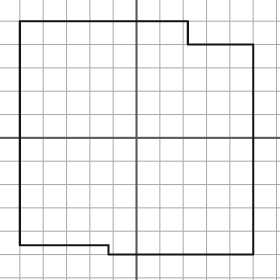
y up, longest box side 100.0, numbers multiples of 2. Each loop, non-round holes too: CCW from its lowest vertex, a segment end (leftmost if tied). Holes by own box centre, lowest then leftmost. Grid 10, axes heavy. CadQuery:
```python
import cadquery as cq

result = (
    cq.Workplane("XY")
    .moveTo(-12.0, -50.0)
    .lineTo(50.0, -50.0)
    .lineTo(50.0, 40.0)
    .lineTo(22.0, 40.0)
    .lineTo(22.0, 50.0)
    .lineTo(-50.0, 50.0)
    .lineTo(-50.0, -46.0)
    .lineTo(-12.0, -46.0)
    .close()
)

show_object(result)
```